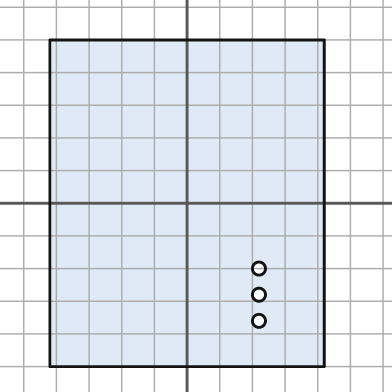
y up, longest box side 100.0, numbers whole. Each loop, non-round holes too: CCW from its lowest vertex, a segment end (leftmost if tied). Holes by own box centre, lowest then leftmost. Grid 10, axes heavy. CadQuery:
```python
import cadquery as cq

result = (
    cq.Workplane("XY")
    .moveTo(-42.0, -50.0)
    .lineTo(42.0, -50.0)
    .lineTo(42.0, 50.0)
    .lineTo(-42.0, 50.0)
    .close()
    .moveTo(22.0, -36.0)
    .circle(2.0)
    .moveTo(22.0, -28.0)
    .circle(2.0)
    .moveTo(22.0, -20.0)
    .circle(2.0)
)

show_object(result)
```